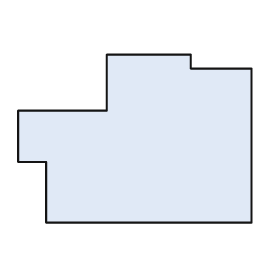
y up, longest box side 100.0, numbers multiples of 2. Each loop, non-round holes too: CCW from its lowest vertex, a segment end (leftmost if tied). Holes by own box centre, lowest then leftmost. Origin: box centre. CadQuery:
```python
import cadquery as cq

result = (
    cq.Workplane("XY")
    .moveTo(-38.0, -36.0)
    .lineTo(50.0, -36.0)
    .lineTo(50.0, 30.0)
    .lineTo(24.0, 30.0)
    .lineTo(24.0, 36.0)
    .lineTo(-12.0, 36.0)
    .lineTo(-12.0, 12.0)
    .lineTo(-50.0, 12.0)
    .lineTo(-50.0, -10.0)
    .lineTo(-38.0, -10.0)
    .close()
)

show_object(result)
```